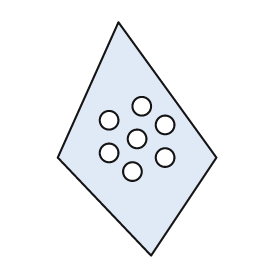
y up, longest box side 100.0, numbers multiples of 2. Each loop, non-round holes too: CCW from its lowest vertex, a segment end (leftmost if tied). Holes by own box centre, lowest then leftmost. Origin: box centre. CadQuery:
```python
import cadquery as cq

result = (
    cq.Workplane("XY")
    .moveTo(6.0, -50.0)
    .lineTo(34.0, -8.0)
    .lineTo(-8.0, 50.0)
    .lineTo(-34.0, -8.0)
    .close()
    .moveTo(-2.0, -14.0)
    .circle(4.0)
    .moveTo(12.0, -8.0)
    .circle(4.0)
    .moveTo(-12.0, -6.0)
    .circle(4.0)
    .moveTo(0.0, 0.0)
    .circle(4.0)
    .moveTo(12.0, 6.0)
    .circle(4.0)
    .moveTo(-12.0, 8.0)
    .circle(4.0)
    .moveTo(2.0, 14.0)
    .circle(4.0)
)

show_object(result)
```